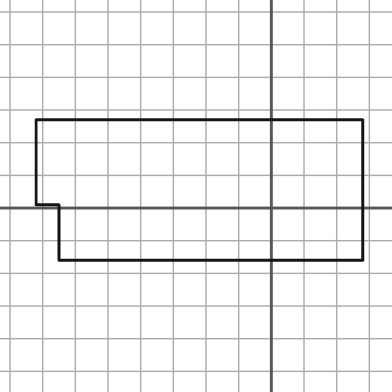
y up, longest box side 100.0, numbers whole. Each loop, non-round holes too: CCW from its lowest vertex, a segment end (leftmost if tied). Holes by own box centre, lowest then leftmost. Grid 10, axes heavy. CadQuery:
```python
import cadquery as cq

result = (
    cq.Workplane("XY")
    .moveTo(-65.0, -16.0)
    .lineTo(28.0, -16.0)
    .lineTo(28.0, 27.0)
    .lineTo(-72.0, 27.0)
    .lineTo(-72.0, 1.0)
    .lineTo(-65.0, 1.0)
    .close()
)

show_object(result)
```